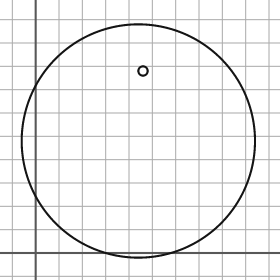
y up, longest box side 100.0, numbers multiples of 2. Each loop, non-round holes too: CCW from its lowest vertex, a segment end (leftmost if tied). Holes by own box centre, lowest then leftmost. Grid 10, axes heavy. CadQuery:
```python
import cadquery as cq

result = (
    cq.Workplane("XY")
    .moveTo(44.0, 48.0)
    .circle(50.0)
    .moveTo(46.0, 78.0)
    .circle(2.0)
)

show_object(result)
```